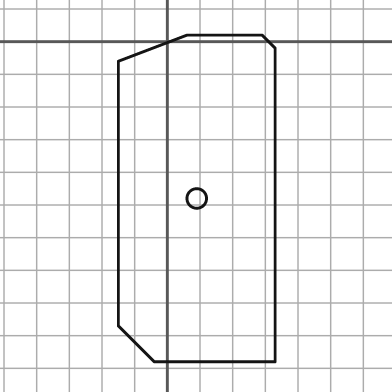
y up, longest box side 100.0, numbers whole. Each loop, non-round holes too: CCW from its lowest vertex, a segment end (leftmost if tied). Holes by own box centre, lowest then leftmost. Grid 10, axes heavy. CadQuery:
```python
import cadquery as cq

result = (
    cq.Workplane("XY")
    .moveTo(-4.0, -98.0)
    .lineTo(33.0, -98.0)
    .lineTo(33.0, -2.0)
    .lineTo(29.0, 2.0)
    .lineTo(6.0, 2.0)
    .lineTo(-15.0, -6.0)
    .lineTo(-15.0, -87.0)
    .close()
    .moveTo(9.0, -48.0)
    .circle(3.0)
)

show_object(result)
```